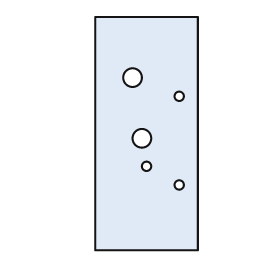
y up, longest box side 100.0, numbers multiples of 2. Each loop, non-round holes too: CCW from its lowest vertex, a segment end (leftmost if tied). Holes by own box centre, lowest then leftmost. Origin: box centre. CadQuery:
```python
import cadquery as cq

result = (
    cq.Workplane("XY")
    .moveTo(-22.0, -50.0)
    .lineTo(22.0, -50.0)
    .lineTo(22.0, 50.0)
    .lineTo(-22.0, 50.0)
    .close()
    .moveTo(14.0, -22.0)
    .circle(2.0)
    .moveTo(0.0, -14.0)
    .circle(2.0)
    .moveTo(-2.0, -2.0)
    .circle(4.0)
    .moveTo(14.0, 16.0)
    .circle(2.0)
    .moveTo(-6.0, 24.0)
    .circle(4.0)
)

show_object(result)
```